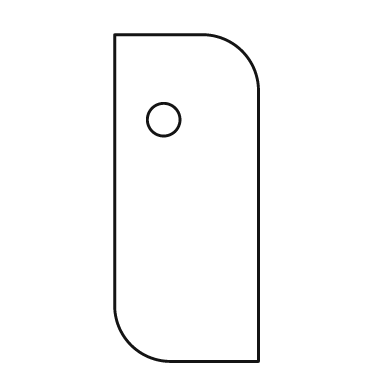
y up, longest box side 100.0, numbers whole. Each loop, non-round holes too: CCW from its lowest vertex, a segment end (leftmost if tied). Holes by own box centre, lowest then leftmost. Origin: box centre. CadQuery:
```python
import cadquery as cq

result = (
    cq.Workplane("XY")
    .moveTo(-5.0, -50.0)
    .lineTo(22.0, -50.0)
    .lineTo(22.0, 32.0)
    .threePointArc((17.0, 45.0), (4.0, 50.0))
    .lineTo(-22.0, 50.0)
    .lineTo(-22.0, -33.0)
    .threePointArc((-17.0, -45.0), (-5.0, -50.0))
    .close()
    .moveTo(-7.0, 24.0)
    .circle(5.0)
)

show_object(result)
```